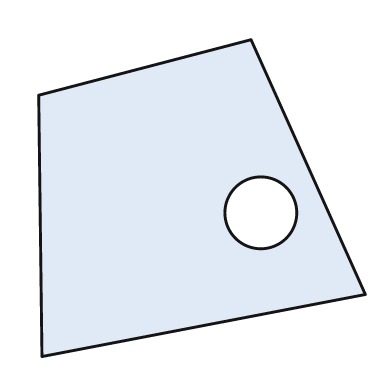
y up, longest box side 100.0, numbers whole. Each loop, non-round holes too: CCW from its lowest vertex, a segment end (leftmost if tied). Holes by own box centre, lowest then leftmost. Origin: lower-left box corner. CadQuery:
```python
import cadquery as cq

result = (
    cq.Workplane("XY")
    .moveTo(1.0, 0.0)
    .lineTo(100.0, 19.0)
    .lineTo(65.0, 97.0)
    .lineTo(0.0, 80.0)
    .close()
    .moveTo(68.0, 44.0)
    .circle(11.0)
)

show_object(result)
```